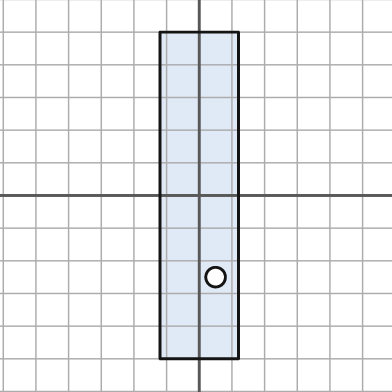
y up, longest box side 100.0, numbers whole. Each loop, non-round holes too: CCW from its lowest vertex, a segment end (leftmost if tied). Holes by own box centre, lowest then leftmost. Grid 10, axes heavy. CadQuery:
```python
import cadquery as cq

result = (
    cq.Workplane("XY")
    .moveTo(-12.0, -50.0)
    .lineTo(12.0, -50.0)
    .lineTo(12.0, 50.0)
    .lineTo(-12.0, 50.0)
    .close()
    .moveTo(5.0, -25.0)
    .circle(3.0)
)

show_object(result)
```